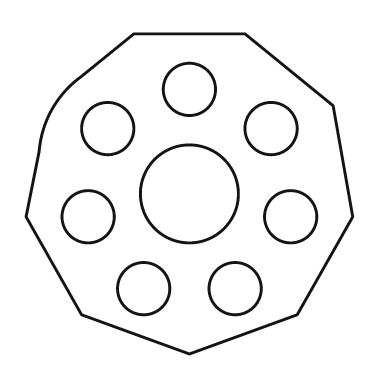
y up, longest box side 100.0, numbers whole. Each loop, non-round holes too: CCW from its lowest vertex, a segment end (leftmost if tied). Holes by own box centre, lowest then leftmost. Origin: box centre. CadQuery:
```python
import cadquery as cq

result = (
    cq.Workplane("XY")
    .moveTo(0.0, -49.0)
    .lineTo(33.0, -37.0)
    .lineTo(50.0, -7.0)
    .lineTo(44.0, 27.0)
    .lineTo(17.0, 49.0)
    .lineTo(-17.0, 49.0)
    .lineTo(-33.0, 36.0)
    .threePointArc((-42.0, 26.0), (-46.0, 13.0))
    .lineTo(-50.0, -7.0)
    .lineTo(-33.0, -37.0)
    .close()
    .moveTo(-14.0, -29.0)
    .circle(8.0)
    .moveTo(14.0, -29.0)
    .circle(8.0)
    .moveTo(-31.0, -7.0)
    .circle(8.0)
    .moveTo(31.0, -7.0)
    .circle(8.0)
    .moveTo(0.0, 0.0)
    .circle(15.0)
    .moveTo(-25.0, 20.0)
    .circle(8.0)
    .moveTo(25.0, 20.0)
    .circle(8.0)
    .moveTo(0.0, 32.0)
    .circle(8.0)
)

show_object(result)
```